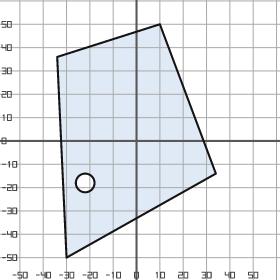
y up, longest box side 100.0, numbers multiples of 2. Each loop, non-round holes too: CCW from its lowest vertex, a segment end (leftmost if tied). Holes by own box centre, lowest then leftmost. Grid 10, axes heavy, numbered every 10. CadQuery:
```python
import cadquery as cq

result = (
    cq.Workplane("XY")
    .moveTo(-30.0, -50.0)
    .lineTo(34.0, -14.0)
    .lineTo(10.0, 50.0)
    .lineTo(-34.0, 36.0)
    .close()
    .moveTo(-22.0, -18.0)
    .circle(4.0)
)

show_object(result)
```